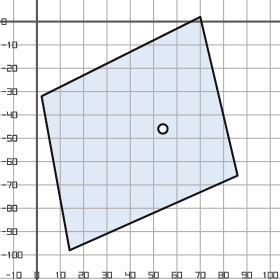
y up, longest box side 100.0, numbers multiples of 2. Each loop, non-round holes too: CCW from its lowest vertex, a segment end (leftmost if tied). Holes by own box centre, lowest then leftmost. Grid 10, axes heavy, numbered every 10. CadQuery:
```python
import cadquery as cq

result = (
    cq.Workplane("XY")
    .moveTo(14.0, -98.0)
    .lineTo(86.0, -66.0)
    .lineTo(70.0, 2.0)
    .lineTo(2.0, -32.0)
    .close()
    .moveTo(54.0, -46.0)
    .circle(2.0)
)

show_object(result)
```